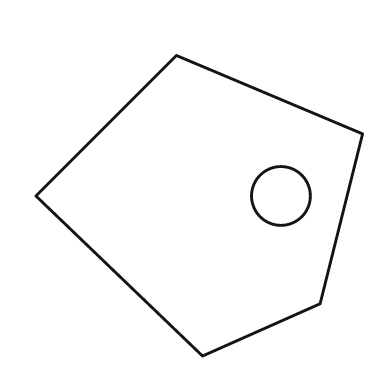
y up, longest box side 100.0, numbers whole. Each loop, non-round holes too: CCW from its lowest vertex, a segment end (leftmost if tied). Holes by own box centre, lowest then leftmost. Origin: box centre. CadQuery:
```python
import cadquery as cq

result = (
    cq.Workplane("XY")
    .moveTo(1.0, -46.0)
    .lineTo(37.0, -30.0)
    .lineTo(50.0, 22.0)
    .lineTo(-7.0, 46.0)
    .lineTo(-50.0, 3.0)
    .close()
    .moveTo(25.0, 3.0)
    .circle(9.0)
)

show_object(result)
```